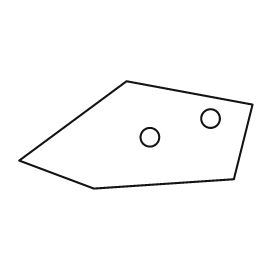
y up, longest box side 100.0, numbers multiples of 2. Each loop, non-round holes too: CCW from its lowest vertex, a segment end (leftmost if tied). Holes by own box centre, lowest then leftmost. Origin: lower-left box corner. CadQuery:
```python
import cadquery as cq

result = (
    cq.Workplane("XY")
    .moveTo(32.0, 0.0)
    .lineTo(92.0, 4.0)
    .lineTo(100.0, 36.0)
    .lineTo(46.0, 46.0)
    .lineTo(0.0, 12.0)
    .close()
    .moveTo(56.0, 22.0)
    .circle(4.0)
    .moveTo(82.0, 30.0)
    .circle(4.0)
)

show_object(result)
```